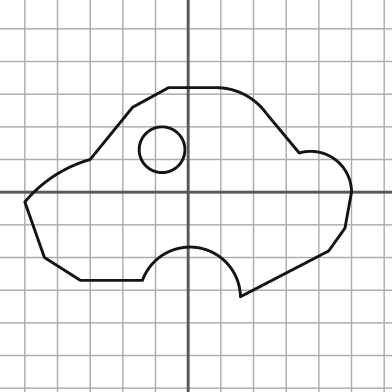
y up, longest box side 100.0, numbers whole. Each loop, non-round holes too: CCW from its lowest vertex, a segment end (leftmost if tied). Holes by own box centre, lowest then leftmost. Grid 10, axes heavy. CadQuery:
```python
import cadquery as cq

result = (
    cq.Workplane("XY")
    .moveTo(16.0, -32.0)
    .lineTo(43.0, -18.0)
    .lineTo(48.0, -11.0)
    .lineTo(50.0, 0.0)
    .threePointArc((45.0, 10.0), (34.0, 12.0))
    .lineTo(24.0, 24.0)
    .threePointArc((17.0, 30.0), (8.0, 32.0))
    .lineTo(-6.0, 32.0)
    .lineTo(-17.0, 26.0)
    .lineTo(-30.0, 10.0)
    .threePointArc((-41.0, 5.0), (-50.0, -3.0))
    .lineTo(-44.0, -20.0)
    .lineTo(-33.0, -27.0)
    .lineTo(-14.0, -27.0)
    .threePointArc((3.0, -17.0), (16.0, -32.0))
    .close()
    .moveTo(-8.0, 13.0)
    .circle(7.0)
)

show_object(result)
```